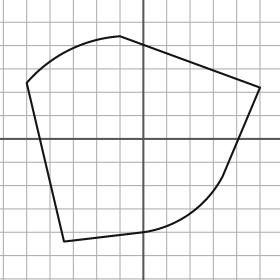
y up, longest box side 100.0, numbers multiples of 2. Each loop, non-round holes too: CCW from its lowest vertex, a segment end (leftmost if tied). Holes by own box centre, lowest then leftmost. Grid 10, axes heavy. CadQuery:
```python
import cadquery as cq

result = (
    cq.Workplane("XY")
    .moveTo(-34.0, -44.0)
    .lineTo(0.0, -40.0)
    .threePointArc((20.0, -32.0), (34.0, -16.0))
    .lineTo(50.0, 22.0)
    .lineTo(-10.0, 44.0)
    .threePointArc((-32.0, 38.0), (-50.0, 24.0))
    .close()
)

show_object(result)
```